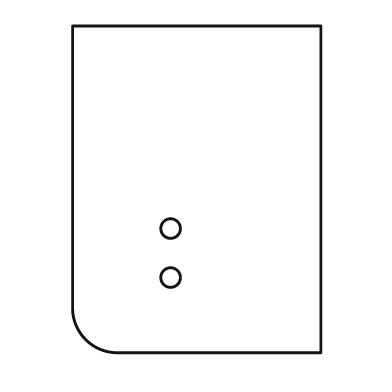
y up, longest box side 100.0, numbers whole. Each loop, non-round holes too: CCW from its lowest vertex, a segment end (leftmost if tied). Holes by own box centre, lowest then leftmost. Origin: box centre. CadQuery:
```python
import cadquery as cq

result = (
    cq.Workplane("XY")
    .moveTo(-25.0, -50.0)
    .lineTo(38.0, -50.0)
    .lineTo(38.0, 50.0)
    .lineTo(-38.0, 50.0)
    .lineTo(-38.0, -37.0)
    .threePointArc((-34.0, -46.0), (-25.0, -50.0))
    .close()
    .moveTo(-8.0, -27.0)
    .circle(3.0)
    .moveTo(-8.0, -12.0)
    .circle(3.0)
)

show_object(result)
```